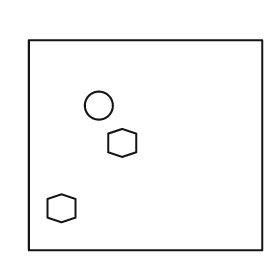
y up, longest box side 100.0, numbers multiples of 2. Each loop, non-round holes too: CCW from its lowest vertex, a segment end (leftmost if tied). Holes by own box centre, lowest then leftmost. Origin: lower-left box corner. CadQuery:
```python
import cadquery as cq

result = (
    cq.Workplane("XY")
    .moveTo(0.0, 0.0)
    .lineTo(100.0, 0.0)
    .lineTo(100.0, 90.0)
    .lineTo(0.0, 90.0)
    .close()
    .moveTo(14.0, 12.0)
    .lineTo(20.0, 14.0)
    .lineTo(20.0, 22.0)
    .lineTo(14.0, 24.0)
    .lineTo(8.0, 22.0)
    .lineTo(8.0, 14.0)
    .close()
    .moveTo(40.0, 40.0)
    .lineTo(46.0, 42.0)
    .lineTo(46.0, 50.0)
    .lineTo(40.0, 52.0)
    .lineTo(34.0, 50.0)
    .lineTo(34.0, 42.0)
    .close()
    .moveTo(30.0, 62.0)
    .circle(6.0)
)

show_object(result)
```